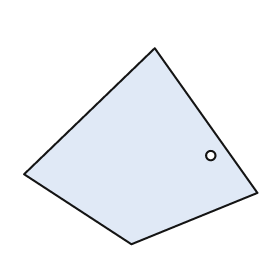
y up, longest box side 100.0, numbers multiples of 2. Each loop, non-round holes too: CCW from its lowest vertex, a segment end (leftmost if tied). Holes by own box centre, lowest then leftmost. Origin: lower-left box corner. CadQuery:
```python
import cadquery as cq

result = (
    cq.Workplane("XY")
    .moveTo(46.0, 0.0)
    .lineTo(100.0, 22.0)
    .lineTo(56.0, 84.0)
    .lineTo(0.0, 30.0)
    .close()
    .moveTo(80.0, 38.0)
    .circle(2.0)
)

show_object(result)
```